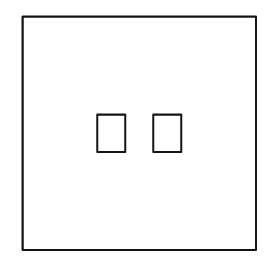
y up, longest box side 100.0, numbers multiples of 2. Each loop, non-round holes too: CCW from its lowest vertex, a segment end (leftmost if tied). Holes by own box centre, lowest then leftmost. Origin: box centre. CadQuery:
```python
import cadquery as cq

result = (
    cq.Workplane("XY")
    .moveTo(-50.0, -50.0)
    .lineTo(50.0, -50.0)
    .lineTo(50.0, 50.0)
    .lineTo(-50.0, 50.0)
    .close()
    .moveTo(-18.0, -8.0)
    .lineTo(-6.0, -8.0)
    .lineTo(-6.0, 8.0)
    .lineTo(-18.0, 8.0)
    .close()
    .moveTo(6.0, -8.0)
    .lineTo(18.0, -8.0)
    .lineTo(18.0, 8.0)
    .lineTo(6.0, 8.0)
    .close()
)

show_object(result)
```